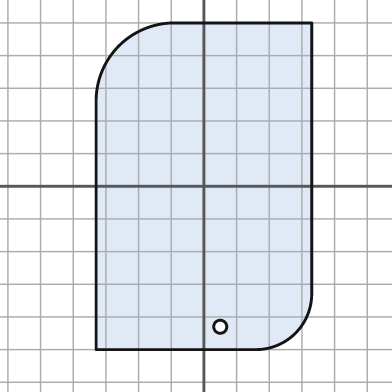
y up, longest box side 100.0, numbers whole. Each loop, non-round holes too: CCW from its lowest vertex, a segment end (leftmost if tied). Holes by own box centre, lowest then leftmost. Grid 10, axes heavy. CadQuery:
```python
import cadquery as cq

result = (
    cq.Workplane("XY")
    .moveTo(-33.0, -50.0)
    .lineTo(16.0, -50.0)
    .threePointArc((28.0, -45.0), (33.0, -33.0))
    .lineTo(33.0, 50.0)
    .lineTo(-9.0, 50.0)
    .threePointArc((-26.0, 43.0), (-33.0, 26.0))
    .close()
    .moveTo(5.0, -43.0)
    .circle(2.0)
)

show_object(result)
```